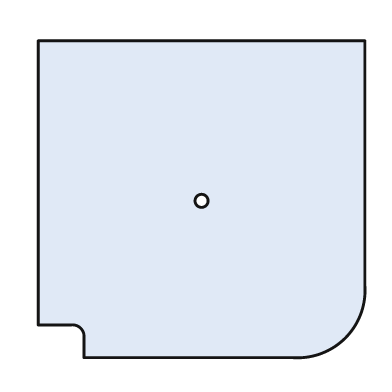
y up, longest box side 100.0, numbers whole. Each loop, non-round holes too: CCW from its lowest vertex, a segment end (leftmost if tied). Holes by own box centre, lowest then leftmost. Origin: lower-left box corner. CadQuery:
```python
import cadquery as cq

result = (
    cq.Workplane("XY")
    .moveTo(14.0, 0.0)
    .lineTo(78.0, 0.0)
    .threePointArc((94.0, 6.0), (100.0, 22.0))
    .lineTo(100.0, 97.0)
    .lineTo(0.0, 97.0)
    .lineTo(0.0, 10.0)
    .lineTo(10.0, 10.0)
    .threePointArc((13.0, 9.0), (14.0, 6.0))
    .close()
    .moveTo(50.0, 48.0)
    .circle(2.0)
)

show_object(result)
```